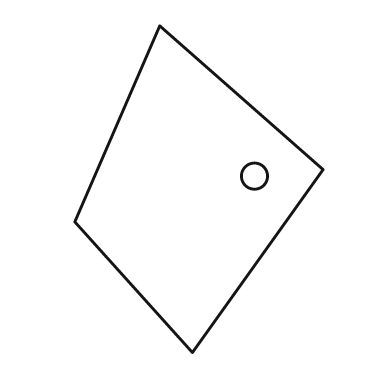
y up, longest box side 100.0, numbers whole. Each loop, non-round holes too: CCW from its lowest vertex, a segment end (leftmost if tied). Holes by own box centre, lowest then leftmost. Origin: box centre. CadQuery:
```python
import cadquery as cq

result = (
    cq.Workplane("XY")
    .moveTo(-2.0, -50.0)
    .lineTo(38.0, 6.0)
    .lineTo(-12.0, 50.0)
    .lineTo(-38.0, -10.0)
    .close()
    .moveTo(17.0, 4.0)
    .circle(4.0)
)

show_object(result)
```